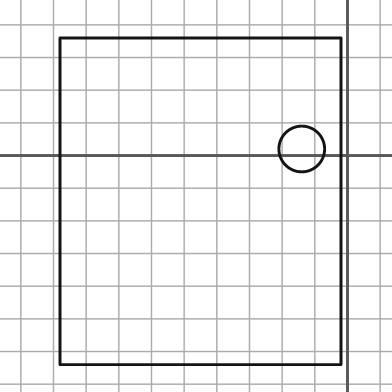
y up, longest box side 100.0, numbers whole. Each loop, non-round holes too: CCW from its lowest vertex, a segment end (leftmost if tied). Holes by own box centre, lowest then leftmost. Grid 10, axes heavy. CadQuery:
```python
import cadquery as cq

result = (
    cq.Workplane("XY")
    .moveTo(-88.0, -64.0)
    .lineTo(-2.0, -64.0)
    .lineTo(-2.0, 36.0)
    .lineTo(-88.0, 36.0)
    .close()
    .moveTo(-14.0, 2.0)
    .circle(7.0)
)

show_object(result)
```